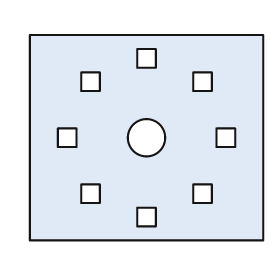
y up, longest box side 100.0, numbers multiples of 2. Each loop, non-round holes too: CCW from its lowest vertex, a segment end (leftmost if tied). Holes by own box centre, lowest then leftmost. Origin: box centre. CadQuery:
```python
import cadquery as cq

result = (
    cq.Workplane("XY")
    .moveTo(-50.0, -44.0)
    .lineTo(50.0, -44.0)
    .lineTo(50.0, 44.0)
    .lineTo(-50.0, 44.0)
    .close()
    .moveTo(-4.0, -38.0)
    .lineTo(4.0, -38.0)
    .lineTo(4.0, -30.0)
    .lineTo(-4.0, -30.0)
    .close()
    .moveTo(-28.0, -28.0)
    .lineTo(-20.0, -28.0)
    .lineTo(-20.0, -20.0)
    .lineTo(-28.0, -20.0)
    .close()
    .moveTo(20.0, -28.0)
    .lineTo(28.0, -28.0)
    .lineTo(28.0, -20.0)
    .lineTo(20.0, -20.0)
    .close()
    .moveTo(-38.0, -4.0)
    .lineTo(-30.0, -4.0)
    .lineTo(-30.0, 4.0)
    .lineTo(-38.0, 4.0)
    .close()
    .moveTo(0.0, 0.0)
    .circle(8.0)
    .moveTo(30.0, -4.0)
    .lineTo(38.0, -4.0)
    .lineTo(38.0, 4.0)
    .lineTo(30.0, 4.0)
    .close()
    .moveTo(-28.0, 20.0)
    .lineTo(-20.0, 20.0)
    .lineTo(-20.0, 28.0)
    .lineTo(-28.0, 28.0)
    .close()
    .moveTo(20.0, 20.0)
    .lineTo(28.0, 20.0)
    .lineTo(28.0, 28.0)
    .lineTo(20.0, 28.0)
    .close()
    .moveTo(-4.0, 30.0)
    .lineTo(4.0, 30.0)
    .lineTo(4.0, 38.0)
    .lineTo(-4.0, 38.0)
    .close()
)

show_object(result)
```